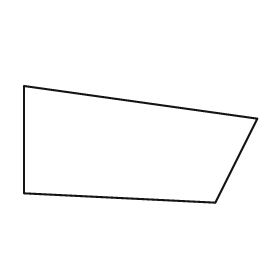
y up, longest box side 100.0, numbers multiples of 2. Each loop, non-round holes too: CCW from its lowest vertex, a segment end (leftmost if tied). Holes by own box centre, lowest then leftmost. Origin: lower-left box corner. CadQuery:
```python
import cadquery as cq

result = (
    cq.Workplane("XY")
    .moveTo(82.0, 0.0)
    .lineTo(100.0, 36.0)
    .lineTo(0.0, 50.0)
    .lineTo(0.0, 4.0)
    .close()
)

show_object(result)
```